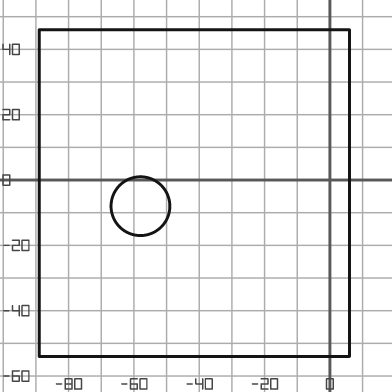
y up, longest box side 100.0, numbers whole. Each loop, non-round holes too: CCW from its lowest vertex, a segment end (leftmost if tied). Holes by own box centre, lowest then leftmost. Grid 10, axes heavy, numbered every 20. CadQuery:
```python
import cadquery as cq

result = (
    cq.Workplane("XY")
    .moveTo(-89.0, -54.0)
    .lineTo(6.0, -54.0)
    .lineTo(6.0, 46.0)
    .lineTo(-89.0, 46.0)
    .close()
    .moveTo(-58.0, -8.0)
    .circle(9.0)
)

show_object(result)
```